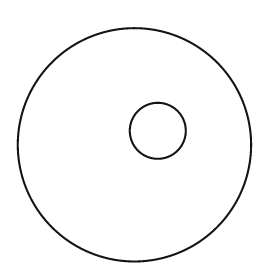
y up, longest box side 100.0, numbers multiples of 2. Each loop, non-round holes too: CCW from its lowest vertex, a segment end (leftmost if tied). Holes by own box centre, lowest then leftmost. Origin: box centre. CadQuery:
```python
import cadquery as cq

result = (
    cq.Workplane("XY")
    .moveTo(0.0, 0.0)
    .circle(50.0)
    .moveTo(10.0, 6.0)
    .circle(12.0)
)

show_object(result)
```